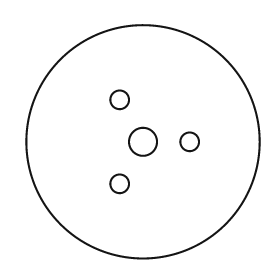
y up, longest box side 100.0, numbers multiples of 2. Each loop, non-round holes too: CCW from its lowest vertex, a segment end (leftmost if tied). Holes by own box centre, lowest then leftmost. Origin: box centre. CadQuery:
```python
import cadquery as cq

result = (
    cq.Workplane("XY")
    .moveTo(0.0, 0.0)
    .circle(50.0)
    .moveTo(-10.0, -18.0)
    .circle(4.0)
    .moveTo(0.0, 0.0)
    .circle(6.0)
    .moveTo(20.0, 0.0)
    .circle(4.0)
    .moveTo(-10.0, 18.0)
    .circle(4.0)
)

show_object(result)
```